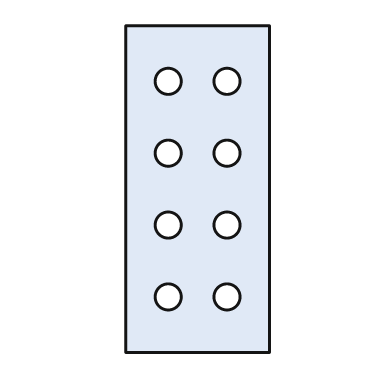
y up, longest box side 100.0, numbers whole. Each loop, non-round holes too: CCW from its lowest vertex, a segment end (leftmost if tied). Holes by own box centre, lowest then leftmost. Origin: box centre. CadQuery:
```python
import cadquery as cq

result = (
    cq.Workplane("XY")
    .moveTo(-22.0, -50.0)
    .lineTo(22.0, -50.0)
    .lineTo(22.0, 50.0)
    .lineTo(-22.0, 50.0)
    .close()
    .moveTo(-9.0, -33.0)
    .circle(4.0)
    .moveTo(9.0, -33.0)
    .circle(4.0)
    .moveTo(-9.0, -11.0)
    .circle(4.0)
    .moveTo(9.0, -11.0)
    .circle(4.0)
    .moveTo(-9.0, 11.0)
    .circle(4.0)
    .moveTo(9.0, 11.0)
    .circle(4.0)
    .moveTo(-9.0, 33.0)
    .circle(4.0)
    .moveTo(9.0, 33.0)
    .circle(4.0)
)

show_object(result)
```